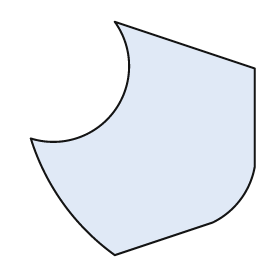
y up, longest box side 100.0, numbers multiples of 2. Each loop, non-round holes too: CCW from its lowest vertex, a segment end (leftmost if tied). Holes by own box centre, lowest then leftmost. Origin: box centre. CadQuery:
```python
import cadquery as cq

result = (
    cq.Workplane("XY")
    .moveTo(-12.0, -50.0)
    .lineTo(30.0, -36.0)
    .threePointArc((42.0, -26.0), (48.0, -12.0))
    .lineTo(48.0, 30.0)
    .lineTo(-12.0, 50.0)
    .threePointArc((-12.0, 12.0), (-48.0, 0.0))
    .threePointArc((-34.0, -28.0), (-12.0, -50.0))
    .close()
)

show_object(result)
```